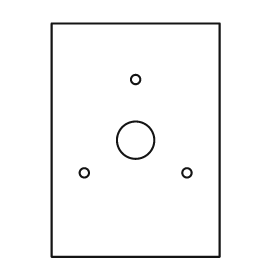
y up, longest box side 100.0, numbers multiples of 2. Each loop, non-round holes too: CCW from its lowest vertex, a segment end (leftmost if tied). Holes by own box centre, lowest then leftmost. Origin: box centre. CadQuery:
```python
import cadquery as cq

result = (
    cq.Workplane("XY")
    .moveTo(-36.0, -50.0)
    .lineTo(36.0, -50.0)
    .lineTo(36.0, 50.0)
    .lineTo(-36.0, 50.0)
    .close()
    .moveTo(-22.0, -14.0)
    .circle(2.0)
    .moveTo(22.0, -14.0)
    .circle(2.0)
    .moveTo(0.0, 0.0)
    .circle(8.0)
    .moveTo(0.0, 26.0)
    .circle(2.0)
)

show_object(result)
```